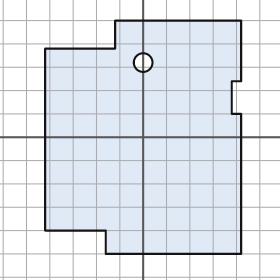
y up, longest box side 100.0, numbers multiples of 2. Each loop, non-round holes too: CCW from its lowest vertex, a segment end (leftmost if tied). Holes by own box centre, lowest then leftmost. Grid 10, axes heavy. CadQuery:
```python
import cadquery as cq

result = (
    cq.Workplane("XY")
    .moveTo(-16.0, -50.0)
    .lineTo(42.0, -50.0)
    .lineTo(42.0, 10.0)
    .lineTo(38.0, 10.0)
    .lineTo(38.0, 24.0)
    .lineTo(42.0, 24.0)
    .lineTo(42.0, 50.0)
    .lineTo(-12.0, 50.0)
    .lineTo(-12.0, 38.0)
    .lineTo(-42.0, 38.0)
    .lineTo(-42.0, -40.0)
    .lineTo(-16.0, -40.0)
    .close()
    .moveTo(0.0, 32.0)
    .circle(4.0)
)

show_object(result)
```